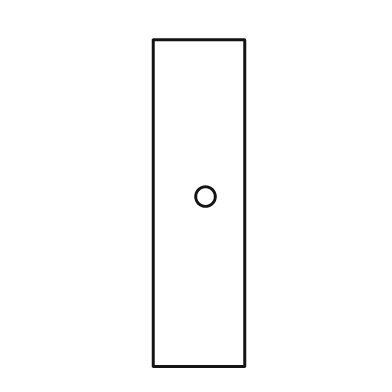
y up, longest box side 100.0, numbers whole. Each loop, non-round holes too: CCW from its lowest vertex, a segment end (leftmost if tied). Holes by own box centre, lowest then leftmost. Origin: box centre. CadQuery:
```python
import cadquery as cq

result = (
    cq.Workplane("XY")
    .moveTo(-14.0, -50.0)
    .lineTo(14.0, -50.0)
    .lineTo(14.0, 50.0)
    .lineTo(-14.0, 50.0)
    .close()
    .moveTo(2.0, 2.0)
    .circle(3.0)
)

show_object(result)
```